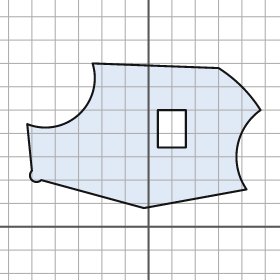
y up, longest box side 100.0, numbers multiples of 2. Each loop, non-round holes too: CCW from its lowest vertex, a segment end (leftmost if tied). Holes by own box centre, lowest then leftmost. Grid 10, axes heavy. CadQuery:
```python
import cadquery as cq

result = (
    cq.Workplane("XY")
    .moveTo(-2.0, 8.0)
    .lineTo(42.0, 16.0)
    .threePointArc((38.0, 34.0), (48.0, 50.0))
    .threePointArc((40.0, 60.0), (30.0, 68.0))
    .lineTo(-24.0, 70.0)
    .threePointArc((-30.0, 48.0), (-52.0, 44.0))
    .lineTo(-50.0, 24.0)
    .threePointArc((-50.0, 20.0), (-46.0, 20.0))
    .close()
    .moveTo(4.0, 34.0)
    .lineTo(16.0, 34.0)
    .lineTo(16.0, 50.0)
    .lineTo(4.0, 50.0)
    .close()
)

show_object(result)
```